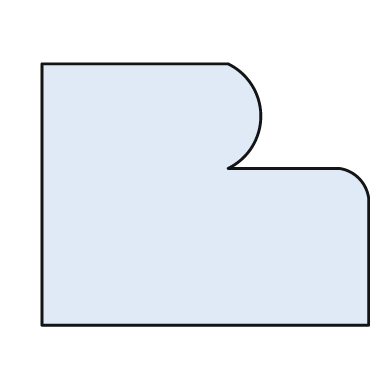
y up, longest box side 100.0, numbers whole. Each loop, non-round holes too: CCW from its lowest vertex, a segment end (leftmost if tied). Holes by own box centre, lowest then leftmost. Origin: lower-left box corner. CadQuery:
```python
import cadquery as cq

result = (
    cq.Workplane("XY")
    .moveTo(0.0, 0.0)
    .lineTo(100.0, 0.0)
    .lineTo(100.0, 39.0)
    .threePointArc((97.0, 45.0), (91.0, 48.0))
    .lineTo(57.0, 48.0)
    .threePointArc((67.0, 64.0), (57.0, 80.0))
    .lineTo(0.0, 80.0)
    .close()
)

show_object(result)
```